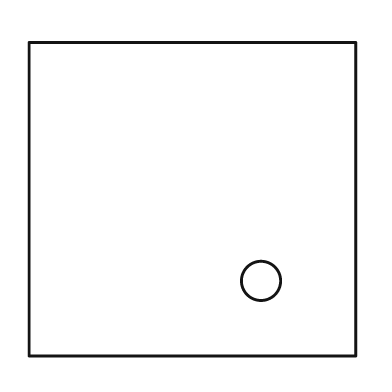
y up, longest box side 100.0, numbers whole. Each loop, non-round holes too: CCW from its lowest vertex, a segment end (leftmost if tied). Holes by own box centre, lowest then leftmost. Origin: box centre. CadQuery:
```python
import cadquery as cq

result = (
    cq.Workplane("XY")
    .moveTo(-50.0, -48.0)
    .lineTo(50.0, -48.0)
    .lineTo(50.0, 48.0)
    .lineTo(-50.0, 48.0)
    .close()
    .moveTo(21.0, -25.0)
    .circle(6.0)
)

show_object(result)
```